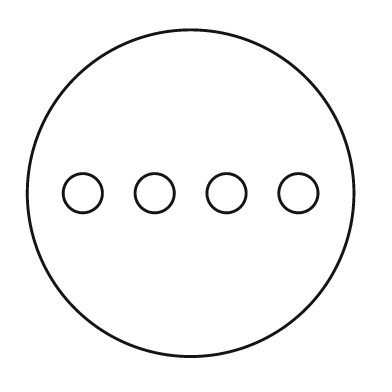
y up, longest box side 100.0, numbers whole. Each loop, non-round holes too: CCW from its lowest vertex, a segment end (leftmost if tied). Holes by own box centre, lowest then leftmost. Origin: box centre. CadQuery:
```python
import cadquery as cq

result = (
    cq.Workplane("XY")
    .moveTo(0.0, 0.0)
    .circle(50.0)
    .moveTo(-33.0, 0.0)
    .circle(6.0)
    .moveTo(-11.0, 0.0)
    .circle(6.0)
    .moveTo(11.0, 0.0)
    .circle(6.0)
    .moveTo(33.0, 0.0)
    .circle(6.0)
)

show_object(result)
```